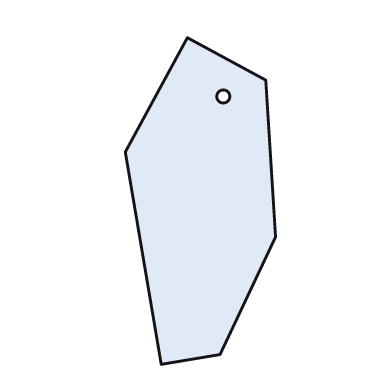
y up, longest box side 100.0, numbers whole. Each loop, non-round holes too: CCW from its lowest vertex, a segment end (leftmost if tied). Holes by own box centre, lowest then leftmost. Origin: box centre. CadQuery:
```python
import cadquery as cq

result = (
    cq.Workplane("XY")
    .moveTo(-12.0, -50.0)
    .lineTo(6.0, -47.0)
    .lineTo(23.0, -11.0)
    .lineTo(20.0, 37.0)
    .lineTo(-4.0, 50.0)
    .lineTo(-23.0, 15.0)
    .close()
    .moveTo(7.0, 32.0)
    .circle(2.0)
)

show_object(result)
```